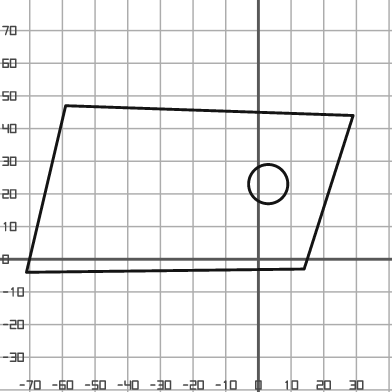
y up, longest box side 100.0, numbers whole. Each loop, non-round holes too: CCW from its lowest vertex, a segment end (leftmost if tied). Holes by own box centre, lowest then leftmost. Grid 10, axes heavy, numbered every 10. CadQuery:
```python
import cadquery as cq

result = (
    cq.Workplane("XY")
    .moveTo(-71.0, -4.0)
    .lineTo(14.0, -3.0)
    .lineTo(29.0, 44.0)
    .lineTo(-59.0, 47.0)
    .close()
    .moveTo(3.0, 23.0)
    .circle(6.0)
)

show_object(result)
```